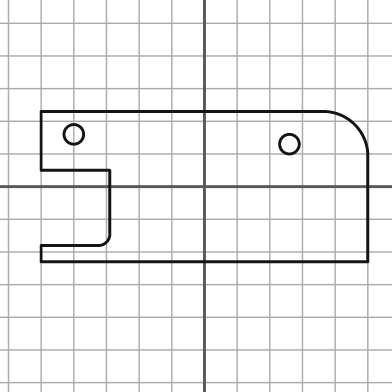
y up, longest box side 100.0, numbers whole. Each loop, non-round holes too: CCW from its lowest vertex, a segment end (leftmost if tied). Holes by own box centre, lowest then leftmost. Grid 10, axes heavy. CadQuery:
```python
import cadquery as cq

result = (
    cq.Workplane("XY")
    .moveTo(-50.0, -23.0)
    .lineTo(50.0, -23.0)
    .lineTo(50.0, 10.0)
    .threePointArc((46.0, 19.0), (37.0, 23.0))
    .lineTo(-50.0, 23.0)
    .lineTo(-50.0, 5.0)
    .lineTo(-29.0, 5.0)
    .lineTo(-29.0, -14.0)
    .threePointArc((-30.0, -17.0), (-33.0, -18.0))
    .lineTo(-50.0, -18.0)
    .close()
    .moveTo(26.0, 13.0)
    .circle(3.0)
    .moveTo(-40.0, 16.0)
    .circle(3.0)
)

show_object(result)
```